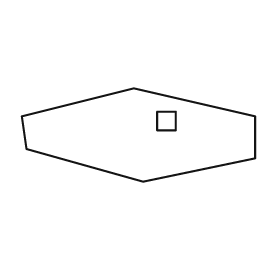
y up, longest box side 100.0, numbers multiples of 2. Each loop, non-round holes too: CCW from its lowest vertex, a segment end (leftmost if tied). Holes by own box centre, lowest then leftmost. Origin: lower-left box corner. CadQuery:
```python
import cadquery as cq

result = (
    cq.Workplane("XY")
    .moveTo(52.0, 0.0)
    .lineTo(100.0, 10.0)
    .lineTo(100.0, 28.0)
    .lineTo(48.0, 40.0)
    .lineTo(0.0, 28.0)
    .lineTo(2.0, 14.0)
    .close()
    .moveTo(58.0, 22.0)
    .lineTo(66.0, 22.0)
    .lineTo(66.0, 30.0)
    .lineTo(58.0, 30.0)
    .close()
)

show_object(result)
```